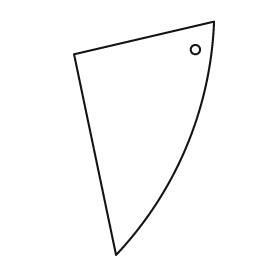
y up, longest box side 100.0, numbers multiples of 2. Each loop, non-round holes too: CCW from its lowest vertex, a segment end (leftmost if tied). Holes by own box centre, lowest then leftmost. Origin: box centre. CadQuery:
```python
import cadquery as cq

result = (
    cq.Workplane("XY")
    .moveTo(-12.0, -50.0)
    .threePointArc((18.0, -4.0), (30.0, 50.0))
    .lineTo(-30.0, 36.0)
    .close()
    .moveTo(22.0, 38.0)
    .circle(2.0)
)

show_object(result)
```